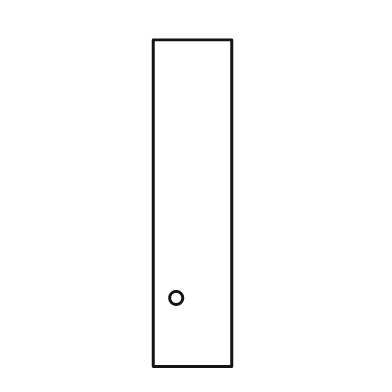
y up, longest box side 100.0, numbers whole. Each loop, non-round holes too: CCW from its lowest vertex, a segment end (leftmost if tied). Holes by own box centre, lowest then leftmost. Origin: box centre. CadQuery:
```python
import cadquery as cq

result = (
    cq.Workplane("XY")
    .moveTo(-12.0, -50.0)
    .lineTo(12.0, -50.0)
    .lineTo(12.0, 50.0)
    .lineTo(-12.0, 50.0)
    .close()
    .moveTo(-5.0, -29.0)
    .circle(2.0)
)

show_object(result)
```